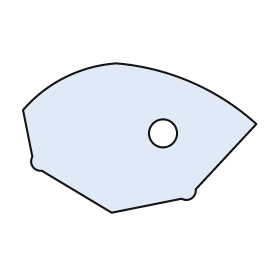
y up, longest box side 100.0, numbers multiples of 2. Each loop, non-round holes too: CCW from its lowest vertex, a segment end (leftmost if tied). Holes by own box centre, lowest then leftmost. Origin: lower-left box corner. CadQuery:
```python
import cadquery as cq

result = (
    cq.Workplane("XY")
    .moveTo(38.0, 0.0)
    .lineTo(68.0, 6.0)
    .threePointArc((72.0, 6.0), (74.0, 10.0))
    .lineTo(100.0, 38.0)
    .threePointArc((72.0, 56.0), (40.0, 64.0))
    .threePointArc((18.0, 58.0), (0.0, 44.0))
    .lineTo(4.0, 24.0)
    .threePointArc((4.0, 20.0), (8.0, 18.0))
    .close()
    .moveTo(60.0, 34.0)
    .circle(6.0)
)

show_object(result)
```